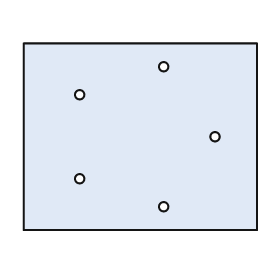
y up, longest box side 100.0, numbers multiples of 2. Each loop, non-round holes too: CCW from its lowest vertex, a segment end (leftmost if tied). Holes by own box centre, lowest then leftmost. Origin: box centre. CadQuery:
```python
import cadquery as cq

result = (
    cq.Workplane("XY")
    .moveTo(-50.0, -40.0)
    .lineTo(50.0, -40.0)
    .lineTo(50.0, 40.0)
    .lineTo(-50.0, 40.0)
    .close()
    .moveTo(10.0, -30.0)
    .circle(2.0)
    .moveTo(-26.0, -18.0)
    .circle(2.0)
    .moveTo(32.0, 0.0)
    .circle(2.0)
    .moveTo(-26.0, 18.0)
    .circle(2.0)
    .moveTo(10.0, 30.0)
    .circle(2.0)
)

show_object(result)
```